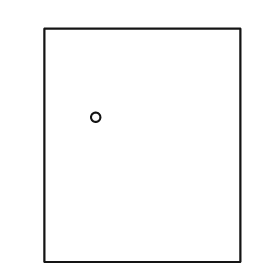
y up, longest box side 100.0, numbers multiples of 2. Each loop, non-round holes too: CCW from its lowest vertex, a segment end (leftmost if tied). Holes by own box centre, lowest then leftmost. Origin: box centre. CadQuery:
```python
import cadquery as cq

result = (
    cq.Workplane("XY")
    .moveTo(-42.0, -50.0)
    .lineTo(42.0, -50.0)
    .lineTo(42.0, 50.0)
    .lineTo(-42.0, 50.0)
    .close()
    .moveTo(-20.0, 12.0)
    .circle(2.0)
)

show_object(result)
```